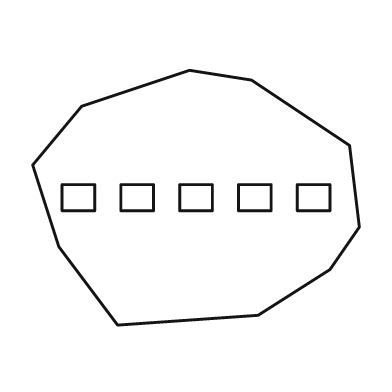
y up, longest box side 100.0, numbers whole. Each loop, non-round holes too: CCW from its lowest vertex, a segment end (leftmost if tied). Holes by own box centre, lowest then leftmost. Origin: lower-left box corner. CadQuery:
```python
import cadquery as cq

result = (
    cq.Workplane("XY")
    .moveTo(26.0, 0.0)
    .lineTo(69.0, 3.0)
    .lineTo(91.0, 17.0)
    .lineTo(100.0, 30.0)
    .lineTo(97.0, 55.0)
    .lineTo(67.0, 75.0)
    .lineTo(48.0, 78.0)
    .lineTo(15.0, 67.0)
    .lineTo(0.0, 49.0)
    .lineTo(8.0, 24.0)
    .close()
    .moveTo(9.0, 35.0)
    .lineTo(19.0, 35.0)
    .lineTo(19.0, 43.0)
    .lineTo(9.0, 43.0)
    .close()
    .moveTo(27.0, 35.0)
    .lineTo(37.0, 35.0)
    .lineTo(37.0, 43.0)
    .lineTo(27.0, 43.0)
    .close()
    .moveTo(45.0, 35.0)
    .lineTo(55.0, 35.0)
    .lineTo(55.0, 43.0)
    .lineTo(45.0, 43.0)
    .close()
    .moveTo(63.0, 35.0)
    .lineTo(73.0, 35.0)
    .lineTo(73.0, 43.0)
    .lineTo(63.0, 43.0)
    .close()
    .moveTo(81.0, 35.0)
    .lineTo(91.0, 35.0)
    .lineTo(91.0, 43.0)
    .lineTo(81.0, 43.0)
    .close()
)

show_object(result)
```